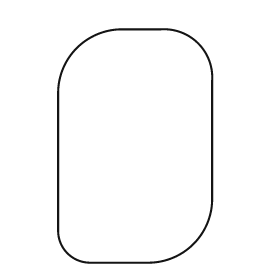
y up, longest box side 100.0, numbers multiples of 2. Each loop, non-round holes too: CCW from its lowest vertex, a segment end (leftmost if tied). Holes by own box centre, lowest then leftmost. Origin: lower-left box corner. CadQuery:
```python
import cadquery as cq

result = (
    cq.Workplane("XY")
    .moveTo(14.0, 0.0)
    .lineTo(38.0, 0.0)
    .threePointArc((58.0, 8.0), (66.0, 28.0))
    .lineTo(66.0, 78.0)
    .threePointArc((60.0, 94.0), (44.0, 100.0))
    .lineTo(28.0, 100.0)
    .threePointArc((8.0, 92.0), (0.0, 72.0))
    .lineTo(0.0, 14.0)
    .threePointArc((4.0, 4.0), (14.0, 0.0))
    .close()
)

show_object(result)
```